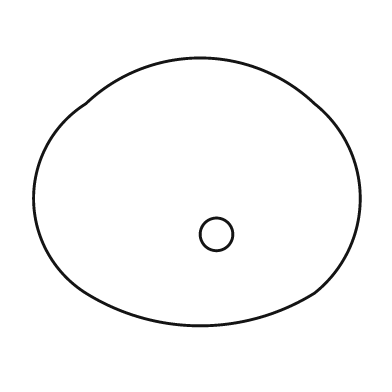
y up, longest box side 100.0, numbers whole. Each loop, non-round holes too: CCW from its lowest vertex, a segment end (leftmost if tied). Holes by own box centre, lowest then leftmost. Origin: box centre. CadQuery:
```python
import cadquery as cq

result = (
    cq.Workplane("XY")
    .moveTo(-34.0, -31.0)
    .threePointArc((1.0, -41.0), (36.0, -31.0))
    .threePointArc((50.0, -2.0), (36.0, 27.0))
    .threePointArc((1.0, 41.0), (-34.0, 27.0))
    .threePointArc((-50.0, -2.0), (-34.0, -31.0))
    .close()
    .moveTo(6.0, -13.0)
    .circle(5.0)
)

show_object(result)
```